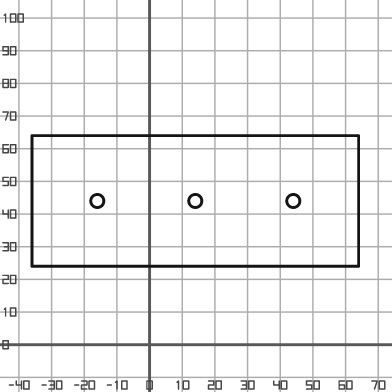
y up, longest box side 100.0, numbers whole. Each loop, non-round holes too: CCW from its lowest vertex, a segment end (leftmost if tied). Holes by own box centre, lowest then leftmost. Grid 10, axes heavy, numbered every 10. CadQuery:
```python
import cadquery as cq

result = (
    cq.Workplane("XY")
    .moveTo(-36.0, 24.0)
    .lineTo(64.0, 24.0)
    .lineTo(64.0, 64.0)
    .lineTo(-36.0, 64.0)
    .close()
    .moveTo(-16.0, 44.0)
    .circle(2.0)
    .moveTo(14.0, 44.0)
    .circle(2.0)
    .moveTo(44.0, 44.0)
    .circle(2.0)
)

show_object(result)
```